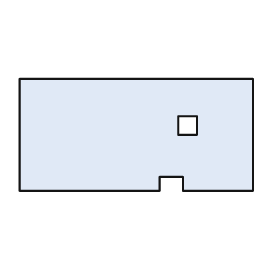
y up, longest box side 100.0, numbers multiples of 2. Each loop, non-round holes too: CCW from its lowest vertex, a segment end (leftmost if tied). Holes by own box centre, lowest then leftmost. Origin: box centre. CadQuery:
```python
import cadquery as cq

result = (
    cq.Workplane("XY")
    .moveTo(-50.0, -24.0)
    .lineTo(10.0, -24.0)
    .lineTo(10.0, -18.0)
    .lineTo(20.0, -18.0)
    .lineTo(20.0, -24.0)
    .lineTo(50.0, -24.0)
    .lineTo(50.0, 24.0)
    .lineTo(-50.0, 24.0)
    .close()
    .moveTo(18.0, 0.0)
    .lineTo(26.0, 0.0)
    .lineTo(26.0, 8.0)
    .lineTo(18.0, 8.0)
    .close()
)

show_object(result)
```